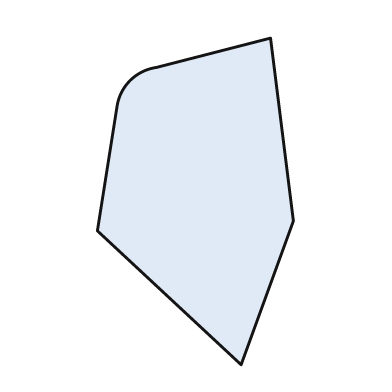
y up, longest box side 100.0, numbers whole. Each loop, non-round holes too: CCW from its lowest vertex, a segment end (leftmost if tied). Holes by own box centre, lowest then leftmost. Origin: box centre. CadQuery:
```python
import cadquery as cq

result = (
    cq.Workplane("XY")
    .moveTo(14.0, -50.0)
    .lineTo(30.0, -6.0)
    .lineTo(23.0, 50.0)
    .lineTo(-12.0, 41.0)
    .threePointArc((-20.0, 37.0), (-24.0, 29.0))
    .lineTo(-30.0, -9.0)
    .close()
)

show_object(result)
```